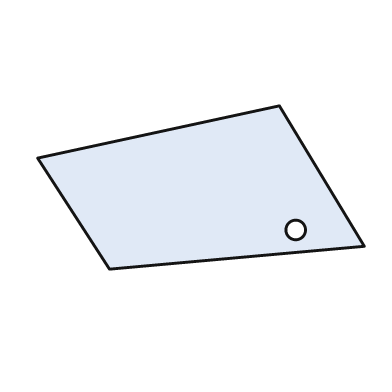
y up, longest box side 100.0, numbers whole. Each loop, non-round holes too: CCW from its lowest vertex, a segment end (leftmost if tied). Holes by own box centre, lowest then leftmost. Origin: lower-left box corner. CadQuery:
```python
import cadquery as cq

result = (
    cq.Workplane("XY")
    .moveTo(22.0, 0.0)
    .lineTo(100.0, 7.0)
    .lineTo(74.0, 50.0)
    .lineTo(0.0, 34.0)
    .close()
    .moveTo(79.0, 12.0)
    .circle(3.0)
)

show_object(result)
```